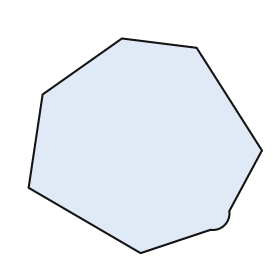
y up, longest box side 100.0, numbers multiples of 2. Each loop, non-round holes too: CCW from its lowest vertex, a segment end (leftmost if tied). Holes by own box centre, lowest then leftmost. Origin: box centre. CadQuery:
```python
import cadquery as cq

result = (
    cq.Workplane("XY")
    .moveTo(-2.0, -46.0)
    .lineTo(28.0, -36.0)
    .threePointArc((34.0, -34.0), (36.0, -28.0))
    .lineTo(50.0, -2.0)
    .lineTo(22.0, 42.0)
    .lineTo(-10.0, 46.0)
    .lineTo(-44.0, 22.0)
    .lineTo(-50.0, -18.0)
    .close()
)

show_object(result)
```